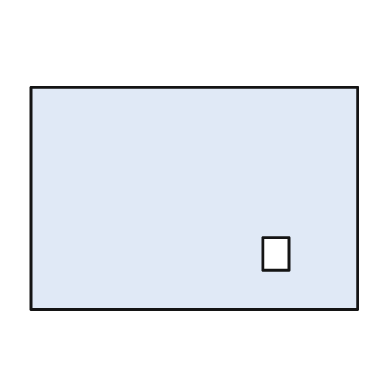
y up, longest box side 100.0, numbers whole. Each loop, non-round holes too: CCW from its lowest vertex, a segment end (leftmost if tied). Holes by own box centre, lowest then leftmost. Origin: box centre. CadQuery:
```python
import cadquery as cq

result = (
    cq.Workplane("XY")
    .moveTo(-50.0, -34.0)
    .lineTo(50.0, -34.0)
    .lineTo(50.0, 34.0)
    .lineTo(-50.0, 34.0)
    .close()
    .moveTo(21.0, -22.0)
    .lineTo(29.0, -22.0)
    .lineTo(29.0, -12.0)
    .lineTo(21.0, -12.0)
    .close()
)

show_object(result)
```